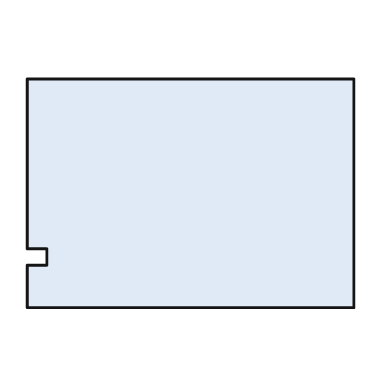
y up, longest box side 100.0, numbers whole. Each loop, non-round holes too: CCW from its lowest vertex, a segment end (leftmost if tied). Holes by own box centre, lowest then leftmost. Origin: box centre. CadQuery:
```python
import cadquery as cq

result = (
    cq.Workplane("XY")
    .moveTo(-50.0, -35.0)
    .lineTo(50.0, -35.0)
    .lineTo(50.0, 35.0)
    .lineTo(-50.0, 35.0)
    .lineTo(-50.0, -17.0)
    .lineTo(-44.0, -17.0)
    .lineTo(-44.0, -22.0)
    .lineTo(-50.0, -22.0)
    .close()
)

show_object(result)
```